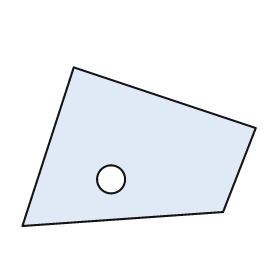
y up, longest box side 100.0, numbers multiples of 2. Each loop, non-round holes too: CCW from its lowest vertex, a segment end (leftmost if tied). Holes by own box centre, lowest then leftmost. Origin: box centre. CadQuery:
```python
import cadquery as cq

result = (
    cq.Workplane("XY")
    .moveTo(-50.0, -34.0)
    .lineTo(36.0, -28.0)
    .lineTo(50.0, 8.0)
    .lineTo(-28.0, 34.0)
    .close()
    .moveTo(-12.0, -14.0)
    .circle(6.0)
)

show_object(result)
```